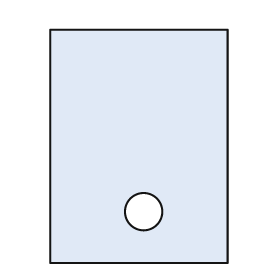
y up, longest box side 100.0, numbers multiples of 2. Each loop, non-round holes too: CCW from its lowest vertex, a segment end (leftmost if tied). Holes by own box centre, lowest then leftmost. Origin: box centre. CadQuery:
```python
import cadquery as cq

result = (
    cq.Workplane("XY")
    .moveTo(-38.0, -50.0)
    .lineTo(38.0, -50.0)
    .lineTo(38.0, 50.0)
    .lineTo(-38.0, 50.0)
    .close()
    .moveTo(2.0, -28.0)
    .circle(8.0)
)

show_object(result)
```